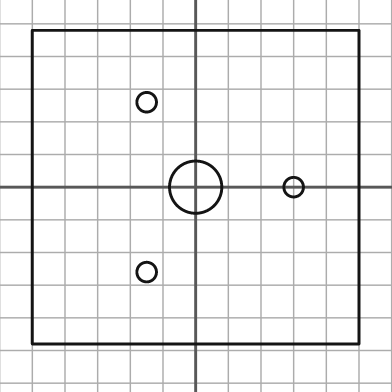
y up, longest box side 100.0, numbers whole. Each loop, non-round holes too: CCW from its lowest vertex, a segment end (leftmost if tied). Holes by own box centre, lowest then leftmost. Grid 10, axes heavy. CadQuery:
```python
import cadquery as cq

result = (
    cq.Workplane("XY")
    .moveTo(-50.0, -48.0)
    .lineTo(50.0, -48.0)
    .lineTo(50.0, 48.0)
    .lineTo(-50.0, 48.0)
    .close()
    .moveTo(-15.0, -26.0)
    .circle(3.0)
    .moveTo(0.0, 0.0)
    .circle(8.0)
    .moveTo(30.0, 0.0)
    .circle(3.0)
    .moveTo(-15.0, 26.0)
    .circle(3.0)
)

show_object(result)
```